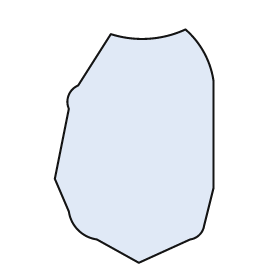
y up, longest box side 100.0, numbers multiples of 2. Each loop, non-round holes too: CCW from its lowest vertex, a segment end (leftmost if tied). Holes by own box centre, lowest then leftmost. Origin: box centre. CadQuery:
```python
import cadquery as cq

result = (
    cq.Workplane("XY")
    .moveTo(2.0, -50.0)
    .lineTo(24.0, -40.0)
    .threePointArc((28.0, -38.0), (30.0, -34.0))
    .lineTo(34.0, -18.0)
    .lineTo(34.0, 28.0)
    .threePointArc((30.0, 40.0), (22.0, 50.0))
    .threePointArc((6.0, 46.0), (-10.0, 48.0))
    .lineTo(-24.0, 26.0)
    .threePointArc((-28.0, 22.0), (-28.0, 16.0))
    .lineTo(-34.0, -14.0)
    .lineTo(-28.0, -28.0)
    .threePointArc((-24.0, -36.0), (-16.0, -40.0))
    .close()
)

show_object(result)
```